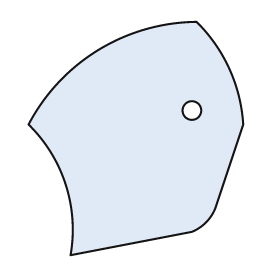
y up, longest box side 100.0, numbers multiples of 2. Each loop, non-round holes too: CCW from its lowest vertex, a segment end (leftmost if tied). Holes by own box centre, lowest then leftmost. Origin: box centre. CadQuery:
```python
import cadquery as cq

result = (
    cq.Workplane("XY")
    .moveTo(-28.0, -50.0)
    .lineTo(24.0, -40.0)
    .threePointArc((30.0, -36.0), (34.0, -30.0))
    .lineTo(46.0, 6.0)
    .threePointArc((40.0, 30.0), (26.0, 50.0))
    .threePointArc((-16.0, 38.0), (-46.0, 6.0))
    .threePointArc((-30.0, -20.0), (-28.0, -50.0))
    .close()
    .moveTo(24.0, 12.0)
    .circle(4.0)
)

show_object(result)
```